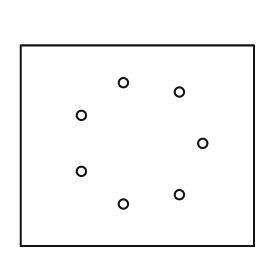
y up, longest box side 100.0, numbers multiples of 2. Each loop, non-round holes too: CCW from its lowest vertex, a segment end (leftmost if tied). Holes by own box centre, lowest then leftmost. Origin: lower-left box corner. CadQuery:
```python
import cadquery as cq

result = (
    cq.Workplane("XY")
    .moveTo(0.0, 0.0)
    .lineTo(100.0, 0.0)
    .lineTo(100.0, 86.0)
    .lineTo(0.0, 86.0)
    .close()
    .moveTo(44.0, 18.0)
    .circle(2.0)
    .moveTo(68.0, 22.0)
    .circle(2.0)
    .moveTo(26.0, 32.0)
    .circle(2.0)
    .moveTo(78.0, 44.0)
    .circle(2.0)
    .moveTo(26.0, 56.0)
    .circle(2.0)
    .moveTo(68.0, 66.0)
    .circle(2.0)
    .moveTo(44.0, 70.0)
    .circle(2.0)
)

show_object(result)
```